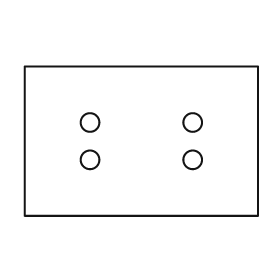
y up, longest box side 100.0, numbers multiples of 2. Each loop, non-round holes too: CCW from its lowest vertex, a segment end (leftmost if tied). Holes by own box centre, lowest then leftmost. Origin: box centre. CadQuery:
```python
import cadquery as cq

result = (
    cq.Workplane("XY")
    .moveTo(-50.0, -32.0)
    .lineTo(50.0, -32.0)
    .lineTo(50.0, 32.0)
    .lineTo(-50.0, 32.0)
    .close()
    .moveTo(-22.0, -8.0)
    .circle(4.0)
    .moveTo(22.0, -8.0)
    .circle(4.0)
    .moveTo(-22.0, 8.0)
    .circle(4.0)
    .moveTo(22.0, 8.0)
    .circle(4.0)
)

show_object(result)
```